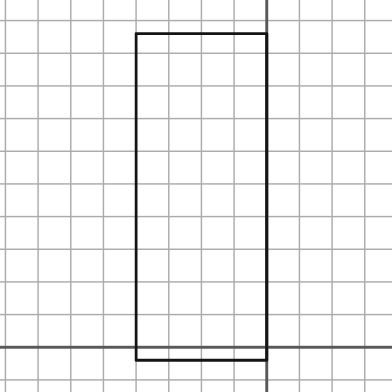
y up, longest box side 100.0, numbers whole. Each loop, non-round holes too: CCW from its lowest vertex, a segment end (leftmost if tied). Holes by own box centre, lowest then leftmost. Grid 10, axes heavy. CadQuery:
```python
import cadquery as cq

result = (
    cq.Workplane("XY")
    .moveTo(-40.0, -4.0)
    .lineTo(0.0, -4.0)
    .lineTo(0.0, 96.0)
    .lineTo(-40.0, 96.0)
    .close()
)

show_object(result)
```